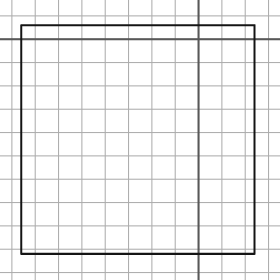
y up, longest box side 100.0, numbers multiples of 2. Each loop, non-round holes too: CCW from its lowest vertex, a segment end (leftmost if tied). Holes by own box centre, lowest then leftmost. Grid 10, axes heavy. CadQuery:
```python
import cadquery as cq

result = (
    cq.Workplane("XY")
    .moveTo(-76.0, -92.0)
    .lineTo(24.0, -92.0)
    .lineTo(24.0, 6.0)
    .lineTo(-76.0, 6.0)
    .close()
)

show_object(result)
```